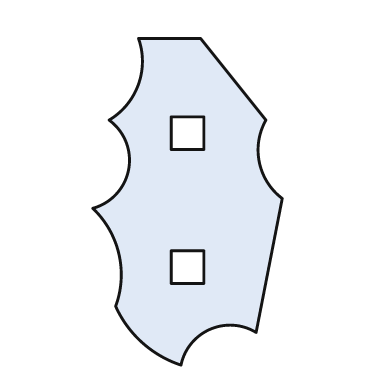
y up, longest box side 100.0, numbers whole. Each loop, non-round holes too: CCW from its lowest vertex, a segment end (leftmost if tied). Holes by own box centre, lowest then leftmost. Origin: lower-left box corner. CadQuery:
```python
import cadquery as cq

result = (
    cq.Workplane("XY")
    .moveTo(27.0, 0.0)
    .threePointArc((36.0, 11.0), (50.0, 10.0))
    .lineTo(58.0, 51.0)
    .threePointArc((51.0, 62.0), (53.0, 75.0))
    .lineTo(33.0, 100.0)
    .lineTo(14.0, 100.0)
    .threePointArc((14.0, 86.0), (5.0, 75.0))
    .threePointArc((11.0, 60.0), (0.0, 48.0))
    .threePointArc((8.0, 34.0), (7.0, 18.0))
    .threePointArc((15.0, 7.0), (27.0, 0.0))
    .close()
    .moveTo(24.0, 25.0)
    .lineTo(34.0, 25.0)
    .lineTo(34.0, 35.0)
    .lineTo(24.0, 35.0)
    .close()
    .moveTo(24.0, 66.0)
    .lineTo(34.0, 66.0)
    .lineTo(34.0, 76.0)
    .lineTo(24.0, 76.0)
    .close()
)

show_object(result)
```